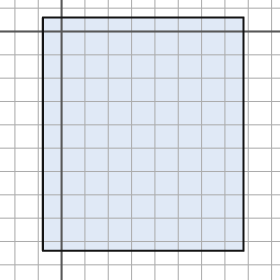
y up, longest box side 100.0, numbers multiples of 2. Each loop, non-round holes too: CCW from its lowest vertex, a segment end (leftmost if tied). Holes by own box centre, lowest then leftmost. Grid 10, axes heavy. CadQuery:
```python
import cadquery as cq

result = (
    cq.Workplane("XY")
    .moveTo(-8.0, -94.0)
    .lineTo(78.0, -94.0)
    .lineTo(78.0, 6.0)
    .lineTo(-8.0, 6.0)
    .close()
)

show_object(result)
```